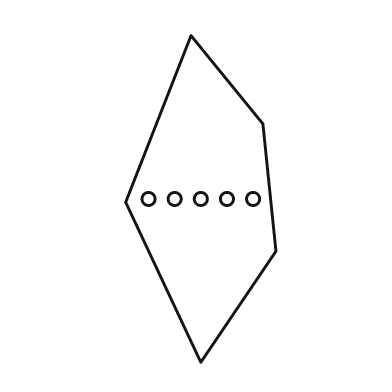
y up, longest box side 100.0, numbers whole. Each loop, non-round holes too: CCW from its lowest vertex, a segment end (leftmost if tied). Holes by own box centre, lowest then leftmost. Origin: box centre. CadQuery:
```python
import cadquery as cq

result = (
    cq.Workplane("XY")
    .moveTo(0.0, -50.0)
    .lineTo(23.0, -16.0)
    .lineTo(19.0, 23.0)
    .lineTo(-3.0, 50.0)
    .lineTo(-23.0, -1.0)
    .close()
    .moveTo(-16.0, 0.0)
    .circle(2.0)
    .moveTo(-8.0, 0.0)
    .circle(2.0)
    .moveTo(0.0, 0.0)
    .circle(2.0)
    .moveTo(8.0, 0.0)
    .circle(2.0)
    .moveTo(16.0, 0.0)
    .circle(2.0)
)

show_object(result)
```